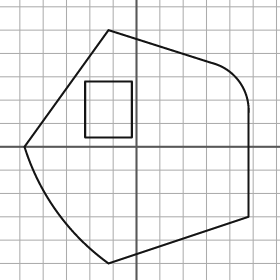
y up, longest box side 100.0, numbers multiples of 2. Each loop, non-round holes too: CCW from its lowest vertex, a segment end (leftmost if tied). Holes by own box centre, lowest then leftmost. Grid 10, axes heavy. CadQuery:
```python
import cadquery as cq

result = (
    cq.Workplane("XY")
    .moveTo(-12.0, -50.0)
    .lineTo(48.0, -30.0)
    .lineTo(48.0, 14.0)
    .threePointArc((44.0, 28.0), (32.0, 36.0))
    .lineTo(-12.0, 50.0)
    .lineTo(-48.0, 0.0)
    .threePointArc((-34.0, -28.0), (-12.0, -50.0))
    .close()
    .moveTo(-22.0, 4.0)
    .lineTo(-2.0, 4.0)
    .lineTo(-2.0, 28.0)
    .lineTo(-22.0, 28.0)
    .close()
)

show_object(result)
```